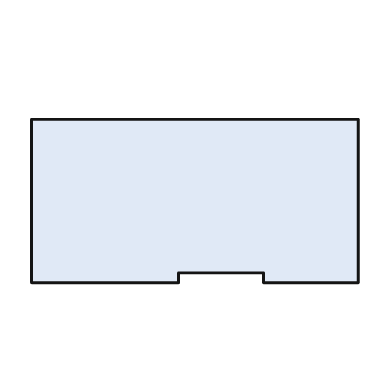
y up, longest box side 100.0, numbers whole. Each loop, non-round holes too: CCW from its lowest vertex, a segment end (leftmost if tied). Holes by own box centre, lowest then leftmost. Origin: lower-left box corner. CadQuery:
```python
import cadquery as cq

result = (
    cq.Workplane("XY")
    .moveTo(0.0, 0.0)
    .lineTo(45.0, 0.0)
    .lineTo(45.0, 3.0)
    .lineTo(71.0, 3.0)
    .lineTo(71.0, 0.0)
    .lineTo(100.0, 0.0)
    .lineTo(100.0, 50.0)
    .lineTo(0.0, 50.0)
    .close()
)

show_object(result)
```